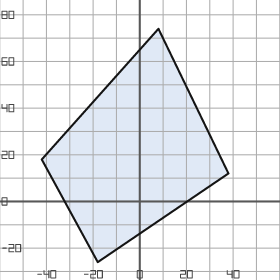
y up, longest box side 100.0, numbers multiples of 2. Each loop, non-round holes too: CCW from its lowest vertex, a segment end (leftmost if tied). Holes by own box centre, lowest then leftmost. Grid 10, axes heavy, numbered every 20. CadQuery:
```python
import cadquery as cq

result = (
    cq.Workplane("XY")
    .moveTo(-18.0, -26.0)
    .lineTo(38.0, 12.0)
    .lineTo(8.0, 74.0)
    .lineTo(-42.0, 18.0)
    .close()
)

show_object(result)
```